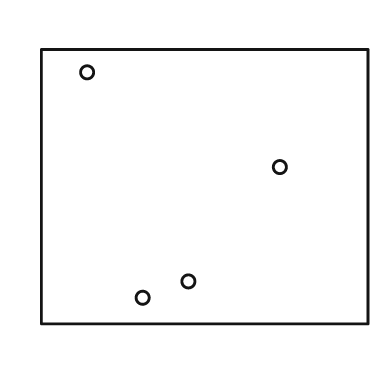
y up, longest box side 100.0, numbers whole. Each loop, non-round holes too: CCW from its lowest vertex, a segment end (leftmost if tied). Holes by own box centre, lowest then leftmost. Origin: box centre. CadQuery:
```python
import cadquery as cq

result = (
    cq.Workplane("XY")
    .moveTo(-50.0, -42.0)
    .lineTo(50.0, -42.0)
    .lineTo(50.0, 42.0)
    .lineTo(-50.0, 42.0)
    .close()
    .moveTo(-19.0, -34.0)
    .circle(2.0)
    .moveTo(-5.0, -29.0)
    .circle(2.0)
    .moveTo(23.0, 6.0)
    .circle(2.0)
    .moveTo(-36.0, 35.0)
    .circle(2.0)
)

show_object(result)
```